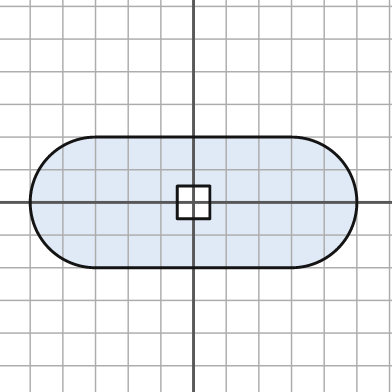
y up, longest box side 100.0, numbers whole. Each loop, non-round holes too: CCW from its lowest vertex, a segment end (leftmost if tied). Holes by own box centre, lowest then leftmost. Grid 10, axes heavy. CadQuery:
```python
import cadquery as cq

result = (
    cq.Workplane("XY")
    .moveTo(-30.0, -20.0)
    .lineTo(30.0, -20.0)
    .threePointArc((50.0, 0.0), (30.0, 20.0))
    .lineTo(-30.0, 20.0)
    .threePointArc((-50.0, 0.0), (-30.0, -20.0))
    .close()
    .moveTo(-5.0, -5.0)
    .lineTo(5.0, -5.0)
    .lineTo(5.0, 5.0)
    .lineTo(-5.0, 5.0)
    .close()
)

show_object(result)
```